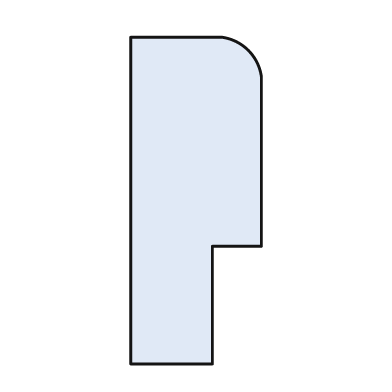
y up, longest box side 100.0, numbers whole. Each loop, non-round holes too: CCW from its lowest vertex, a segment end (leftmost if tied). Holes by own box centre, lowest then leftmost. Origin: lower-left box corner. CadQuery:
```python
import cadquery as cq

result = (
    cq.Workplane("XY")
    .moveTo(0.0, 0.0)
    .lineTo(25.0, 0.0)
    .lineTo(25.0, 36.0)
    .lineTo(40.0, 36.0)
    .lineTo(40.0, 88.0)
    .threePointArc((36.0, 96.0), (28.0, 100.0))
    .lineTo(0.0, 100.0)
    .close()
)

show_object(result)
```